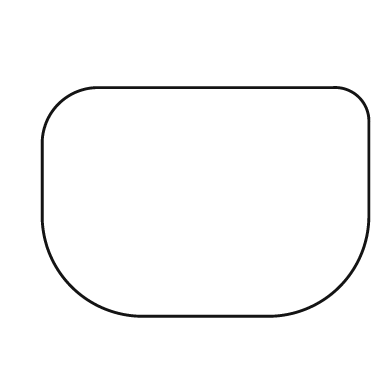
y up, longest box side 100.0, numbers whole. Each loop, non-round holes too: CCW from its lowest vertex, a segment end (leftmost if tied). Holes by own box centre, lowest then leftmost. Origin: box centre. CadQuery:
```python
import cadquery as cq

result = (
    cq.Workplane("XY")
    .moveTo(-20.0, -35.0)
    .lineTo(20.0, -35.0)
    .threePointArc((41.0, -26.0), (50.0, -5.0))
    .lineTo(50.0, 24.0)
    .threePointArc((47.0, 32.0), (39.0, 35.0))
    .lineTo(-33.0, 35.0)
    .threePointArc((-45.0, 30.0), (-50.0, 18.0))
    .lineTo(-50.0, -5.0)
    .threePointArc((-41.0, -26.0), (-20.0, -35.0))
    .close()
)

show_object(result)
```